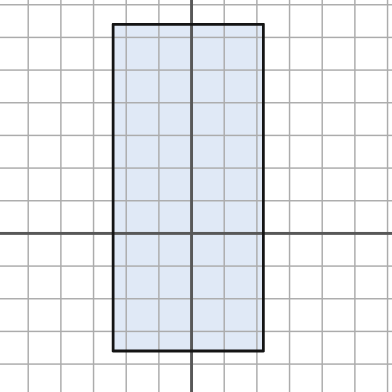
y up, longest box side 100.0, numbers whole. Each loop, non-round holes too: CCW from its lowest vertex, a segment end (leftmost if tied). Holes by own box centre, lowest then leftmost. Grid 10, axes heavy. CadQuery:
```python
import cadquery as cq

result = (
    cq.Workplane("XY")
    .moveTo(-24.0, -36.0)
    .lineTo(22.0, -36.0)
    .lineTo(22.0, 64.0)
    .lineTo(-24.0, 64.0)
    .close()
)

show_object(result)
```